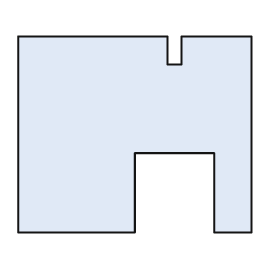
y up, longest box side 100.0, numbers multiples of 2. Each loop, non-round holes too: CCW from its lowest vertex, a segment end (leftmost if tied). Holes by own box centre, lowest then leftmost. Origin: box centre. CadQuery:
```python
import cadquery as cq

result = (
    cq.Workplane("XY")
    .moveTo(-50.0, -42.0)
    .lineTo(0.0, -42.0)
    .lineTo(0.0, -8.0)
    .lineTo(34.0, -8.0)
    .lineTo(34.0, -42.0)
    .lineTo(50.0, -42.0)
    .lineTo(50.0, 42.0)
    .lineTo(20.0, 42.0)
    .lineTo(20.0, 30.0)
    .lineTo(14.0, 30.0)
    .lineTo(14.0, 42.0)
    .lineTo(-50.0, 42.0)
    .close()
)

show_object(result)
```